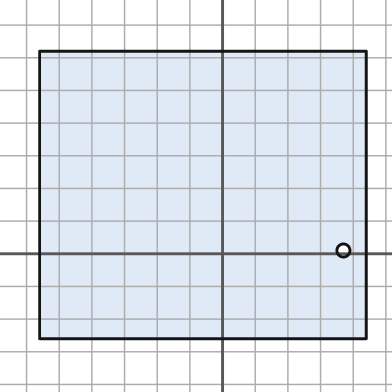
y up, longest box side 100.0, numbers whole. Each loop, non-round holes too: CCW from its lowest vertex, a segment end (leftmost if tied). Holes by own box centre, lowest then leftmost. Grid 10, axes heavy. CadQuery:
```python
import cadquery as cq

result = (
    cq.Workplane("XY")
    .moveTo(-56.0, -26.0)
    .lineTo(44.0, -26.0)
    .lineTo(44.0, 62.0)
    .lineTo(-56.0, 62.0)
    .close()
    .moveTo(37.0, 1.0)
    .circle(2.0)
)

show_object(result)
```